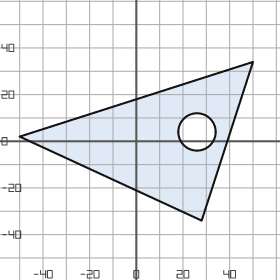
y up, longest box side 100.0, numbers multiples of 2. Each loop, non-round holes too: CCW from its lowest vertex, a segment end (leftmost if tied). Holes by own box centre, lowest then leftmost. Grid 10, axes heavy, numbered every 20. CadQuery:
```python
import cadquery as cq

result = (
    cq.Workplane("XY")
    .moveTo(28.0, -34.0)
    .lineTo(50.0, 34.0)
    .lineTo(-50.0, 2.0)
    .close()
    .moveTo(26.0, 4.0)
    .circle(8.0)
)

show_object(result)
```